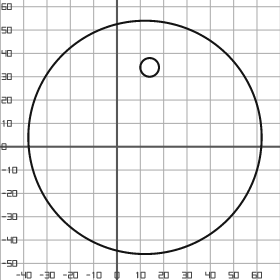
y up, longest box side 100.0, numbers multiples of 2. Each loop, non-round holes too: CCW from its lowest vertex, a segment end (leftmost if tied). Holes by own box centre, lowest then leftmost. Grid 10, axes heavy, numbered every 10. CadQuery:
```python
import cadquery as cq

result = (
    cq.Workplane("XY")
    .moveTo(12.0, 4.0)
    .circle(50.0)
    .moveTo(14.0, 34.0)
    .circle(4.0)
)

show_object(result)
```